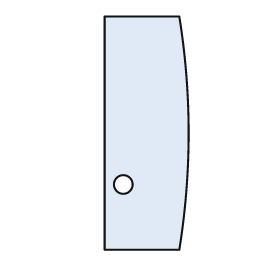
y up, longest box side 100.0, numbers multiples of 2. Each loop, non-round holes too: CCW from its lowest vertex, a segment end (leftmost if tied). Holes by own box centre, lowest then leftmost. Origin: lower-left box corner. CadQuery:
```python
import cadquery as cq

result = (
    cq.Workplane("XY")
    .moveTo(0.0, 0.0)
    .lineTo(32.0, 0.0)
    .threePointArc((36.0, 50.0), (32.0, 100.0))
    .lineTo(0.0, 100.0)
    .close()
    .moveTo(8.0, 28.0)
    .circle(4.0)
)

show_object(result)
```